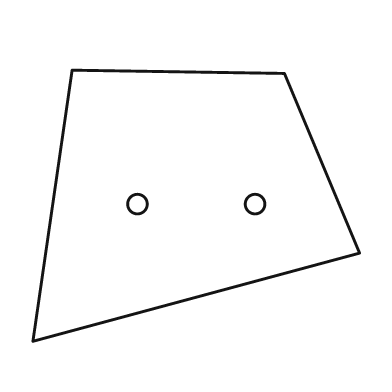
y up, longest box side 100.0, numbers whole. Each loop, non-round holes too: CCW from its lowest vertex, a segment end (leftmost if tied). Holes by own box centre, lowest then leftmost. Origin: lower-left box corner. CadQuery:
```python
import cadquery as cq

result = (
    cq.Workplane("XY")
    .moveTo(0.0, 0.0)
    .lineTo(100.0, 27.0)
    .lineTo(77.0, 82.0)
    .lineTo(12.0, 83.0)
    .close()
    .moveTo(32.0, 42.0)
    .circle(3.0)
    .moveTo(68.0, 42.0)
    .circle(3.0)
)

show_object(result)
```